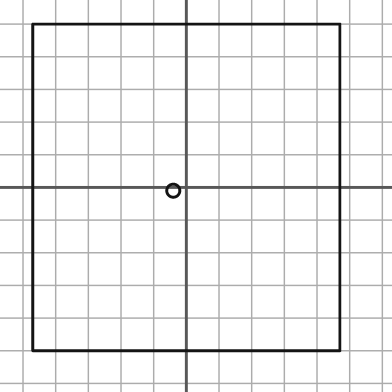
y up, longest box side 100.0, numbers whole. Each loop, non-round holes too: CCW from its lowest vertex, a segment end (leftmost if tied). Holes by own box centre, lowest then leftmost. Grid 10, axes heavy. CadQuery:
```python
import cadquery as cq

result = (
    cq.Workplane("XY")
    .moveTo(-47.0, -50.0)
    .lineTo(47.0, -50.0)
    .lineTo(47.0, 50.0)
    .lineTo(-47.0, 50.0)
    .close()
    .moveTo(-4.0, -1.0)
    .circle(2.0)
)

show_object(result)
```